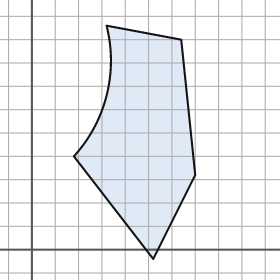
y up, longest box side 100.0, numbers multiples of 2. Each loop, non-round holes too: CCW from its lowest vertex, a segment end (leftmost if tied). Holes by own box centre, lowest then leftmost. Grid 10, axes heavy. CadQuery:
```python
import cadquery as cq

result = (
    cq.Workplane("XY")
    .moveTo(52.0, -4.0)
    .lineTo(70.0, 32.0)
    .lineTo(64.0, 90.0)
    .lineTo(32.0, 96.0)
    .threePointArc((32.0, 66.0), (18.0, 40.0))
    .close()
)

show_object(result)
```